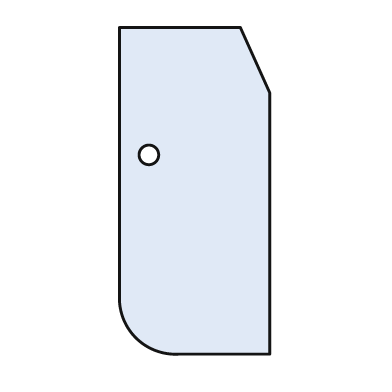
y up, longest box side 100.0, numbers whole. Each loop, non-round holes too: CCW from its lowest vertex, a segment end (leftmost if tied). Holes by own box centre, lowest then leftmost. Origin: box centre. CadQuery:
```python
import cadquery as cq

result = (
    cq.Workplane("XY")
    .moveTo(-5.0, -50.0)
    .lineTo(23.0, -50.0)
    .lineTo(23.0, 30.0)
    .lineTo(14.0, 50.0)
    .lineTo(-23.0, 50.0)
    .lineTo(-23.0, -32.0)
    .threePointArc((-18.0, -45.0), (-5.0, -50.0))
    .close()
    .moveTo(-14.0, 11.0)
    .circle(3.0)
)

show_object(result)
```